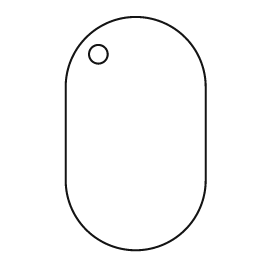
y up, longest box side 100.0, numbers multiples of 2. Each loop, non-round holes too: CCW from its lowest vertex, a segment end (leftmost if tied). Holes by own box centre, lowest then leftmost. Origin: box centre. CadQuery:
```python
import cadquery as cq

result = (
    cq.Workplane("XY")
    .moveTo(-30.0, -20.0)
    .threePointArc((0.0, -50.0), (30.0, -20.0))
    .lineTo(30.0, 20.0)
    .threePointArc((0.0, 50.0), (-30.0, 20.0))
    .close()
    .moveTo(-16.0, 34.0)
    .circle(4.0)
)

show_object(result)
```